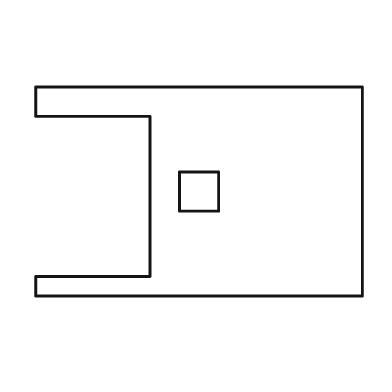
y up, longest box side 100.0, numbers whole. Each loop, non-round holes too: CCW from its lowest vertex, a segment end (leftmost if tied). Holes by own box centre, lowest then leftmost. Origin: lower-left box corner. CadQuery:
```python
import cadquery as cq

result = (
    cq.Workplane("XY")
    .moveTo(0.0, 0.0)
    .lineTo(100.0, 0.0)
    .lineTo(100.0, 64.0)
    .lineTo(0.0, 64.0)
    .lineTo(0.0, 55.0)
    .lineTo(35.0, 55.0)
    .lineTo(35.0, 6.0)
    .lineTo(0.0, 6.0)
    .close()
    .moveTo(44.0, 26.0)
    .lineTo(56.0, 26.0)
    .lineTo(56.0, 38.0)
    .lineTo(44.0, 38.0)
    .close()
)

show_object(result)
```